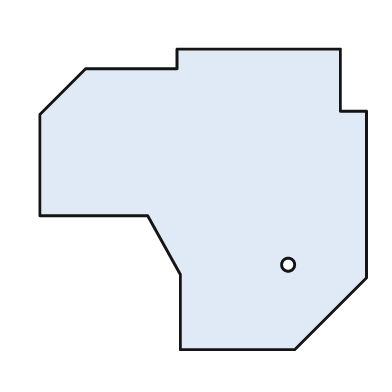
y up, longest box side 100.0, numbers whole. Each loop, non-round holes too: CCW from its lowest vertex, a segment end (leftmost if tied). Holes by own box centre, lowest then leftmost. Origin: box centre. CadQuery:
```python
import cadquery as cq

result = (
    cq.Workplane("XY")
    .moveTo(-7.0, -46.0)
    .lineTo(28.0, -46.0)
    .lineTo(50.0, -24.0)
    .lineTo(50.0, 27.0)
    .lineTo(42.0, 27.0)
    .lineTo(42.0, 46.0)
    .lineTo(-8.0, 46.0)
    .lineTo(-8.0, 40.0)
    .lineTo(-36.0, 40.0)
    .lineTo(-50.0, 26.0)
    .lineTo(-50.0, -5.0)
    .lineTo(-17.0, -5.0)
    .lineTo(-7.0, -23.0)
    .close()
    .moveTo(26.0, -20.0)
    .circle(2.0)
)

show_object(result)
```